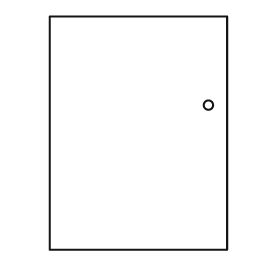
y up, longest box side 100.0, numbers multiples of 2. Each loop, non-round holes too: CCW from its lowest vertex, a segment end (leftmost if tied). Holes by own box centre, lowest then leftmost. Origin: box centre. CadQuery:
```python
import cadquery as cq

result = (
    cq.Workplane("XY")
    .moveTo(-38.0, -50.0)
    .lineTo(38.0, -50.0)
    .lineTo(38.0, 50.0)
    .lineTo(-38.0, 50.0)
    .close()
    .moveTo(30.0, 12.0)
    .circle(2.0)
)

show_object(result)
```